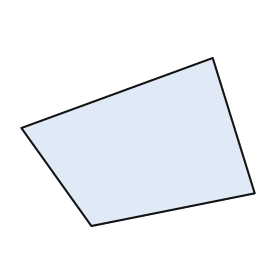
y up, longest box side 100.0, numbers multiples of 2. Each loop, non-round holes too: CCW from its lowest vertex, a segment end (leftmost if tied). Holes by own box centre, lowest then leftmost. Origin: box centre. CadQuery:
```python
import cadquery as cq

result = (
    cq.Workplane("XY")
    .moveTo(-20.0, -36.0)
    .lineTo(50.0, -22.0)
    .lineTo(32.0, 36.0)
    .lineTo(-50.0, 6.0)
    .close()
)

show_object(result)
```